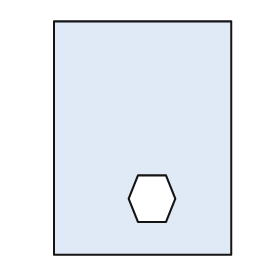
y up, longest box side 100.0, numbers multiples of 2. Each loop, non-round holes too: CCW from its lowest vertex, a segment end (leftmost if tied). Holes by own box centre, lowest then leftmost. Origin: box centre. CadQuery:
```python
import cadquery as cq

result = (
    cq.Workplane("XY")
    .moveTo(-38.0, -50.0)
    .lineTo(38.0, -50.0)
    .lineTo(38.0, 50.0)
    .lineTo(-38.0, 50.0)
    .close()
    .moveTo(-2.0, -36.0)
    .lineTo(10.0, -36.0)
    .lineTo(14.0, -26.0)
    .lineTo(10.0, -16.0)
    .lineTo(-2.0, -16.0)
    .lineTo(-6.0, -26.0)
    .close()
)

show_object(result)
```